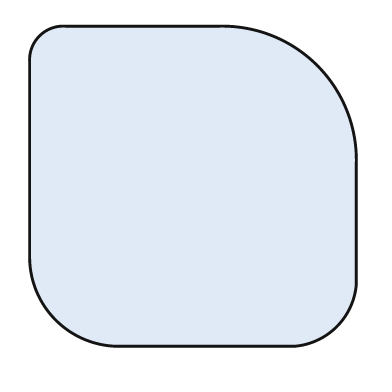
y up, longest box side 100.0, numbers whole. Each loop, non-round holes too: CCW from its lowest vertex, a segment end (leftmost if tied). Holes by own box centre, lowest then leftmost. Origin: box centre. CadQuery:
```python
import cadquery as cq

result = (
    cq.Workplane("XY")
    .moveTo(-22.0, -49.0)
    .lineTo(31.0, -49.0)
    .threePointArc((44.0, -43.0), (50.0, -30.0))
    .lineTo(50.0, 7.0)
    .threePointArc((38.0, 37.0), (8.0, 49.0))
    .lineTo(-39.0, 49.0)
    .threePointArc((-47.0, 46.0), (-50.0, 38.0))
    .lineTo(-50.0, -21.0)
    .threePointArc((-42.0, -41.0), (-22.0, -49.0))
    .close()
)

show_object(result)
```